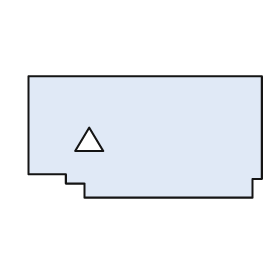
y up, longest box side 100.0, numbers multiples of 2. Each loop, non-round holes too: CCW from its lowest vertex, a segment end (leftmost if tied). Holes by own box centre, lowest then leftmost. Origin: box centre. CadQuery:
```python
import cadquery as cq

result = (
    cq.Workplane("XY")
    .moveTo(-26.0, -26.0)
    .lineTo(46.0, -26.0)
    .lineTo(46.0, -18.0)
    .lineTo(50.0, -18.0)
    .lineTo(50.0, 26.0)
    .lineTo(-50.0, 26.0)
    .lineTo(-50.0, -16.0)
    .lineTo(-34.0, -16.0)
    .lineTo(-34.0, -20.0)
    .lineTo(-26.0, -20.0)
    .close()
    .moveTo(-30.0, -6.0)
    .lineTo(-18.0, -6.0)
    .lineTo(-24.0, 4.0)
    .close()
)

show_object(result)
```